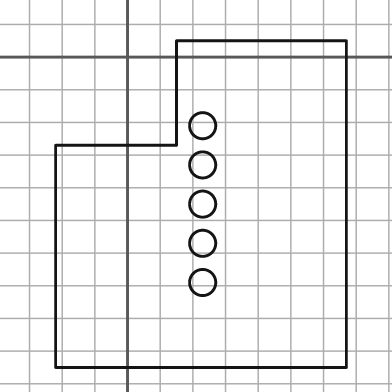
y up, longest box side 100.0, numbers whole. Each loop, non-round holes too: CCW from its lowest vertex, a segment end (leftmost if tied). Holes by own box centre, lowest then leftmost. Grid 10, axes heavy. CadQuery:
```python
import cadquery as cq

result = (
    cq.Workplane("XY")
    .moveTo(-22.0, -95.0)
    .lineTo(67.0, -95.0)
    .lineTo(67.0, 5.0)
    .lineTo(15.0, 5.0)
    .lineTo(15.0, -27.0)
    .lineTo(-22.0, -27.0)
    .close()
    .moveTo(23.0, -69.0)
    .circle(4.0)
    .moveTo(23.0, -57.0)
    .circle(4.0)
    .moveTo(23.0, -45.0)
    .circle(4.0)
    .moveTo(23.0, -33.0)
    .circle(4.0)
    .moveTo(23.0, -21.0)
    .circle(4.0)
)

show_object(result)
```